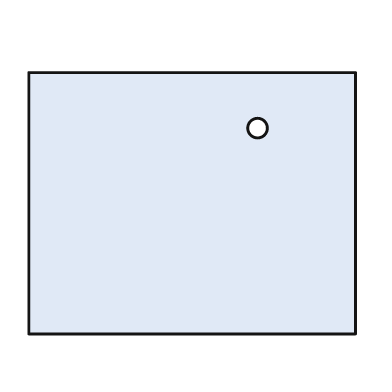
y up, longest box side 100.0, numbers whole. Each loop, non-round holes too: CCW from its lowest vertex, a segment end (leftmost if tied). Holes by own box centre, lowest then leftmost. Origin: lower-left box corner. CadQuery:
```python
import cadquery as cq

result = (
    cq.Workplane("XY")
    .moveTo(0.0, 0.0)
    .lineTo(100.0, 0.0)
    .lineTo(100.0, 80.0)
    .lineTo(0.0, 80.0)
    .close()
    .moveTo(70.0, 63.0)
    .circle(3.0)
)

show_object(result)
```